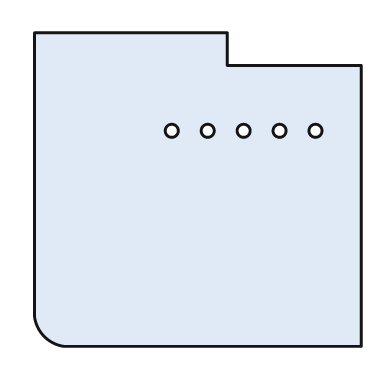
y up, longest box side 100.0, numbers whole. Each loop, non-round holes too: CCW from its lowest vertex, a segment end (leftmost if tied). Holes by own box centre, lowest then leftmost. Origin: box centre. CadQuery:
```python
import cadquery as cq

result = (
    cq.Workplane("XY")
    .moveTo(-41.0, -48.0)
    .lineTo(50.0, -48.0)
    .lineTo(50.0, 38.0)
    .lineTo(9.0, 38.0)
    .lineTo(9.0, 48.0)
    .lineTo(-50.0, 48.0)
    .lineTo(-50.0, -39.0)
    .threePointArc((-47.0, -45.0), (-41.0, -48.0))
    .close()
    .moveTo(-8.0, 18.0)
    .circle(2.0)
    .moveTo(3.0, 18.0)
    .circle(2.0)
    .moveTo(14.0, 18.0)
    .circle(2.0)
    .moveTo(25.0, 18.0)
    .circle(2.0)
    .moveTo(36.0, 18.0)
    .circle(2.0)
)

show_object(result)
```